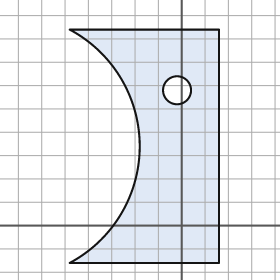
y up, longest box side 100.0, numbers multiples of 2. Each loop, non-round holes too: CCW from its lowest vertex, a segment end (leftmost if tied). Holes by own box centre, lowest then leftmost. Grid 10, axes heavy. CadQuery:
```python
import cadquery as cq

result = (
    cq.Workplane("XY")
    .moveTo(-48.0, -16.0)
    .lineTo(16.0, -16.0)
    .lineTo(16.0, 84.0)
    .lineTo(-48.0, 84.0)
    .threePointArc((-18.0, 34.0), (-48.0, -16.0))
    .close()
    .moveTo(-2.0, 58.0)
    .circle(6.0)
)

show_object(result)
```